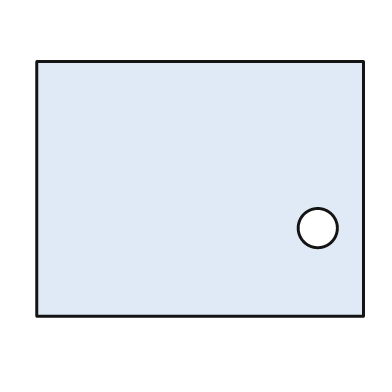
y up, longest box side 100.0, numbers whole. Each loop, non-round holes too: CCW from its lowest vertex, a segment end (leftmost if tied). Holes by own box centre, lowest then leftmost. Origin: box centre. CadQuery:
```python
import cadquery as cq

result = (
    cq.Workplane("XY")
    .moveTo(-50.0, -39.0)
    .lineTo(50.0, -39.0)
    .lineTo(50.0, 39.0)
    .lineTo(-50.0, 39.0)
    .close()
    .moveTo(36.0, -12.0)
    .circle(6.0)
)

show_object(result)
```